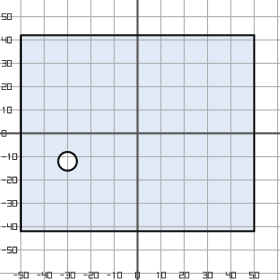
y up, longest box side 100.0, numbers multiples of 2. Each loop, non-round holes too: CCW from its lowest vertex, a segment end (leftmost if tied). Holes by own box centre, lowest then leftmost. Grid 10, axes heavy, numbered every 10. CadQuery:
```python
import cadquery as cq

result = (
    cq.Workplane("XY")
    .moveTo(-50.0, -42.0)
    .lineTo(50.0, -42.0)
    .lineTo(50.0, 42.0)
    .lineTo(-50.0, 42.0)
    .close()
    .moveTo(-30.0, -12.0)
    .circle(4.0)
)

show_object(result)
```